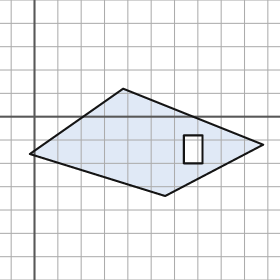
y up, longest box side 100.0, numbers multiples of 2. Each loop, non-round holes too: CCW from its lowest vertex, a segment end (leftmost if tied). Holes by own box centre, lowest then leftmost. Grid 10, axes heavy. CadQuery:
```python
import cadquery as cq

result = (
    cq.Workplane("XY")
    .moveTo(56.0, -34.0)
    .lineTo(98.0, -12.0)
    .lineTo(38.0, 12.0)
    .lineTo(-2.0, -16.0)
    .close()
    .moveTo(64.0, -20.0)
    .lineTo(72.0, -20.0)
    .lineTo(72.0, -8.0)
    .lineTo(64.0, -8.0)
    .close()
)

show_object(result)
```